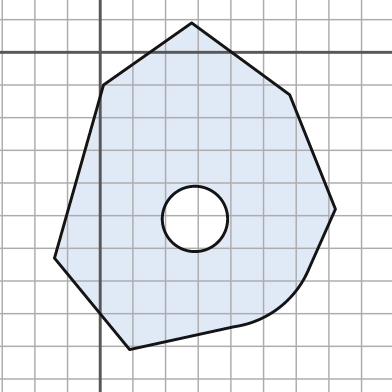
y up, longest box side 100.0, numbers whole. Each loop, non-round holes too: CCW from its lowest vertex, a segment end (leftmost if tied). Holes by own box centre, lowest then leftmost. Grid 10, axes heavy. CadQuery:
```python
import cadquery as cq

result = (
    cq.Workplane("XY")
    .moveTo(9.0, -91.0)
    .lineTo(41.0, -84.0)
    .threePointArc((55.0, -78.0), (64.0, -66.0))
    .lineTo(72.0, -48.0)
    .lineTo(58.0, -13.0)
    .lineTo(28.0, 9.0)
    .lineTo(1.0, -10.0)
    .lineTo(-14.0, -63.0)
    .close()
    .moveTo(29.0, -51.0)
    .circle(10.0)
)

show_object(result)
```